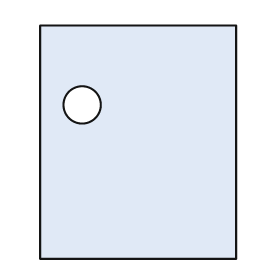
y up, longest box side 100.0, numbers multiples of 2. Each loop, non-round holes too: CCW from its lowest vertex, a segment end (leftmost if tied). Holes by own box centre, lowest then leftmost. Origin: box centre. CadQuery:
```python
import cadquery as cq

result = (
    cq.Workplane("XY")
    .moveTo(-42.0, -50.0)
    .lineTo(42.0, -50.0)
    .lineTo(42.0, 50.0)
    .lineTo(-42.0, 50.0)
    .close()
    .moveTo(-24.0, 16.0)
    .circle(8.0)
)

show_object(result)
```